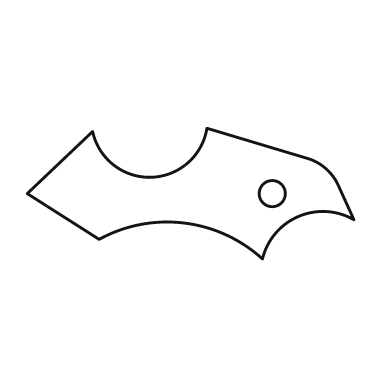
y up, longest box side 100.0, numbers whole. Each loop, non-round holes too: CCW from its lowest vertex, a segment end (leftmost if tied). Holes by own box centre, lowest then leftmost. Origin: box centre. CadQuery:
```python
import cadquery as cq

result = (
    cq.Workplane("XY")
    .moveTo(22.0, -20.0)
    .threePointArc((33.0, -7.0), (50.0, -8.0))
    .lineTo(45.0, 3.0)
    .threePointArc((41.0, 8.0), (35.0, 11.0))
    .lineTo(5.0, 20.0)
    .threePointArc((-12.0, 5.0), (-30.0, 19.0))
    .lineTo(-50.0, 0.0)
    .lineTo(-28.0, -14.0)
    .threePointArc((-2.0, -9.0), (22.0, -20.0))
    .close()
    .moveTo(25.0, 0.0)
    .circle(4.0)
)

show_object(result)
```